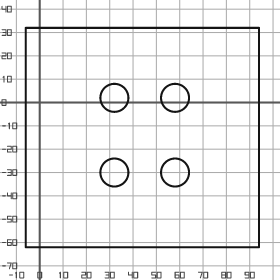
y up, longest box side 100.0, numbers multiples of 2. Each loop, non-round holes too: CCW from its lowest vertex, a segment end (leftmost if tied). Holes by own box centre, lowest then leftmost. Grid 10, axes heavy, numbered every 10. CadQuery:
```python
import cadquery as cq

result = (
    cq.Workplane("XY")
    .moveTo(-6.0, -62.0)
    .lineTo(94.0, -62.0)
    .lineTo(94.0, 32.0)
    .lineTo(-6.0, 32.0)
    .close()
    .moveTo(32.0, -30.0)
    .circle(6.0)
    .moveTo(58.0, -30.0)
    .circle(6.0)
    .moveTo(32.0, 2.0)
    .circle(6.0)
    .moveTo(58.0, 2.0)
    .circle(6.0)
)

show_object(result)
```